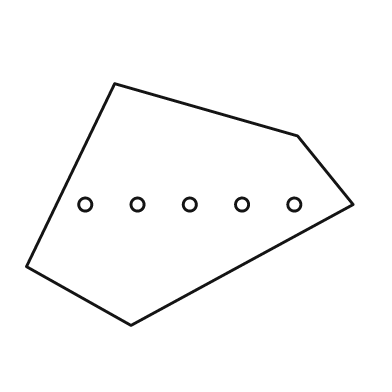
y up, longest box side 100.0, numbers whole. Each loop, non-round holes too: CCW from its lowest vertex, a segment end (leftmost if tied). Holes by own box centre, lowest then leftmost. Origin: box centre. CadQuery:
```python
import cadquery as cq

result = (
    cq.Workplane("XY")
    .moveTo(-18.0, -37.0)
    .lineTo(50.0, 0.0)
    .lineTo(33.0, 21.0)
    .lineTo(-23.0, 37.0)
    .lineTo(-50.0, -19.0)
    .close()
    .moveTo(-32.0, 0.0)
    .circle(2.0)
    .moveTo(-16.0, 0.0)
    .circle(2.0)
    .moveTo(0.0, 0.0)
    .circle(2.0)
    .moveTo(16.0, 0.0)
    .circle(2.0)
    .moveTo(32.0, 0.0)
    .circle(2.0)
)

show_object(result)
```